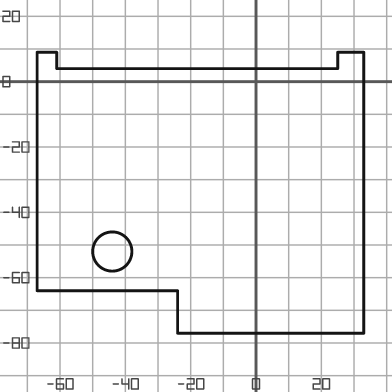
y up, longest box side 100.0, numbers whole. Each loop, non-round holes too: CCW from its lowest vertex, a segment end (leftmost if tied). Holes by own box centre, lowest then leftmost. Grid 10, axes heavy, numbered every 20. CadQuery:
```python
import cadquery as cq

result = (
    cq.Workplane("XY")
    .moveTo(-24.0, -77.0)
    .lineTo(33.0, -77.0)
    .lineTo(33.0, 9.0)
    .lineTo(25.0, 9.0)
    .lineTo(25.0, 4.0)
    .lineTo(-61.0, 4.0)
    .lineTo(-61.0, 9.0)
    .lineTo(-67.0, 9.0)
    .lineTo(-67.0, -64.0)
    .lineTo(-24.0, -64.0)
    .close()
    .moveTo(-44.0, -52.0)
    .circle(6.0)
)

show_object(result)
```